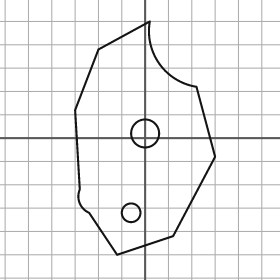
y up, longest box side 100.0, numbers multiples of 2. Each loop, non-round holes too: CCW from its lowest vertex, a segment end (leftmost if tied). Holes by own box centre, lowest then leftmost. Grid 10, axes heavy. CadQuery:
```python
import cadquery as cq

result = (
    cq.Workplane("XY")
    .moveTo(-12.0, -50.0)
    .lineTo(12.0, -42.0)
    .lineTo(30.0, -8.0)
    .lineTo(22.0, 22.0)
    .threePointArc((6.0, 32.0), (2.0, 50.0))
    .lineTo(-20.0, 38.0)
    .lineTo(-30.0, 12.0)
    .lineTo(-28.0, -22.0)
    .threePointArc((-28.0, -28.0), (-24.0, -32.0))
    .close()
    .moveTo(-6.0, -32.0)
    .circle(4.0)
    .moveTo(0.0, 2.0)
    .circle(6.0)
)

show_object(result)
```